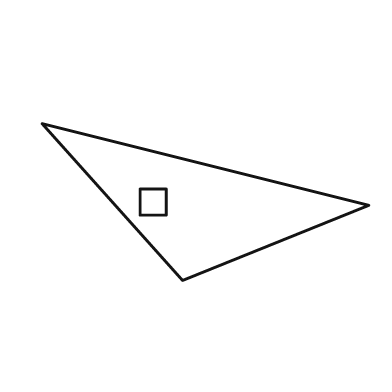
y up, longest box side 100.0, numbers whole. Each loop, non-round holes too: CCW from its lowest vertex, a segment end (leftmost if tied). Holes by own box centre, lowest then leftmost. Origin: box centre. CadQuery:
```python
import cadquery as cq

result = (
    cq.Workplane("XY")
    .moveTo(-7.0, -24.0)
    .lineTo(50.0, -1.0)
    .lineTo(-50.0, 24.0)
    .close()
    .moveTo(-20.0, -4.0)
    .lineTo(-12.0, -4.0)
    .lineTo(-12.0, 4.0)
    .lineTo(-20.0, 4.0)
    .close()
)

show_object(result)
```